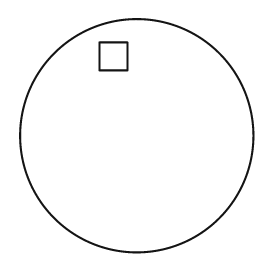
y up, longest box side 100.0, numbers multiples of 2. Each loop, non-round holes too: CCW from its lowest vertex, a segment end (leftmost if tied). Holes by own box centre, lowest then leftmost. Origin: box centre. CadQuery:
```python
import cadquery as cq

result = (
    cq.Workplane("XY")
    .moveTo(0.0, 0.0)
    .circle(50.0)
    .moveTo(-16.0, 28.0)
    .lineTo(-4.0, 28.0)
    .lineTo(-4.0, 40.0)
    .lineTo(-16.0, 40.0)
    .close()
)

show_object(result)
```